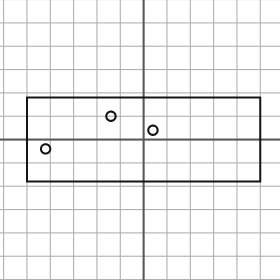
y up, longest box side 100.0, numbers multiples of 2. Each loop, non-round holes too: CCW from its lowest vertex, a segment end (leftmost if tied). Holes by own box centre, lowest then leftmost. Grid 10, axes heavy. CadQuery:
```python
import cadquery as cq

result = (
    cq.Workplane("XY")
    .moveTo(-50.0, -18.0)
    .lineTo(50.0, -18.0)
    .lineTo(50.0, 18.0)
    .lineTo(-50.0, 18.0)
    .close()
    .moveTo(-42.0, -4.0)
    .circle(2.0)
    .moveTo(4.0, 4.0)
    .circle(2.0)
    .moveTo(-14.0, 10.0)
    .circle(2.0)
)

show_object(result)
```